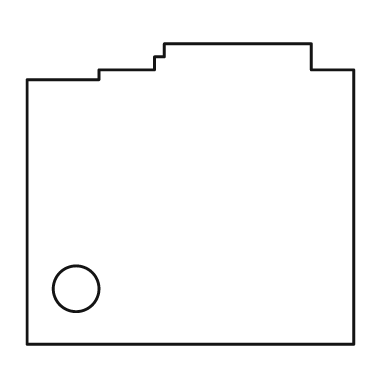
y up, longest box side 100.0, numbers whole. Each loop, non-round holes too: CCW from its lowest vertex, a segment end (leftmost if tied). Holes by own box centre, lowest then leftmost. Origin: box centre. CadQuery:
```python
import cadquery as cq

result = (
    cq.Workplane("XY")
    .moveTo(-50.0, -46.0)
    .lineTo(50.0, -46.0)
    .lineTo(50.0, 38.0)
    .lineTo(37.0, 38.0)
    .lineTo(37.0, 46.0)
    .lineTo(-8.0, 46.0)
    .lineTo(-8.0, 42.0)
    .lineTo(-11.0, 42.0)
    .lineTo(-11.0, 38.0)
    .lineTo(-28.0, 38.0)
    .lineTo(-28.0, 35.0)
    .lineTo(-50.0, 35.0)
    .close()
    .moveTo(-35.0, -29.0)
    .circle(7.0)
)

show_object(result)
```